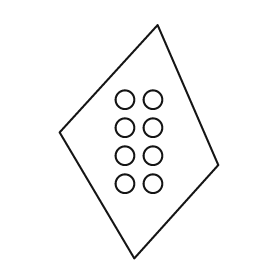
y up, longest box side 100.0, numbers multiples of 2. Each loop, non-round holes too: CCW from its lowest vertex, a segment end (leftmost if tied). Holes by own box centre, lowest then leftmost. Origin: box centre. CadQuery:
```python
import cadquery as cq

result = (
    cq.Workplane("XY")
    .moveTo(-2.0, -50.0)
    .lineTo(34.0, -10.0)
    .lineTo(8.0, 50.0)
    .lineTo(-34.0, 4.0)
    .close()
    .moveTo(-6.0, -18.0)
    .circle(4.0)
    .moveTo(6.0, -18.0)
    .circle(4.0)
    .moveTo(-6.0, -6.0)
    .circle(4.0)
    .moveTo(6.0, -6.0)
    .circle(4.0)
    .moveTo(-6.0, 6.0)
    .circle(4.0)
    .moveTo(6.0, 6.0)
    .circle(4.0)
    .moveTo(-6.0, 18.0)
    .circle(4.0)
    .moveTo(6.0, 18.0)
    .circle(4.0)
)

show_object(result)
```